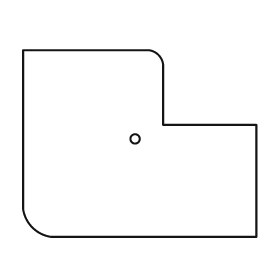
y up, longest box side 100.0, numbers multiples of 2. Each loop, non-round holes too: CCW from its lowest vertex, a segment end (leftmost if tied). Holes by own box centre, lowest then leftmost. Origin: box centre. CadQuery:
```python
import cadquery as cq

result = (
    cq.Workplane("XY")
    .moveTo(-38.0, -40.0)
    .lineTo(50.0, -40.0)
    .lineTo(50.0, 8.0)
    .lineTo(10.0, 8.0)
    .lineTo(10.0, 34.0)
    .threePointArc((8.0, 38.0), (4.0, 40.0))
    .lineTo(-50.0, 40.0)
    .lineTo(-50.0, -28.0)
    .threePointArc((-46.0, -36.0), (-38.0, -40.0))
    .close()
    .moveTo(-2.0, 2.0)
    .circle(2.0)
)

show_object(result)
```